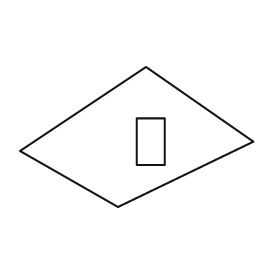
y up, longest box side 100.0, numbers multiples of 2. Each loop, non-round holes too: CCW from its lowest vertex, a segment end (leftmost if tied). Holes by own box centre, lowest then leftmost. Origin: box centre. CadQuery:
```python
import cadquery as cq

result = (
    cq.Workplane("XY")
    .moveTo(-8.0, -30.0)
    .lineTo(50.0, -2.0)
    .lineTo(4.0, 30.0)
    .lineTo(-50.0, -6.0)
    .close()
    .moveTo(0.0, -12.0)
    .lineTo(12.0, -12.0)
    .lineTo(12.0, 8.0)
    .lineTo(0.0, 8.0)
    .close()
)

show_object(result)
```